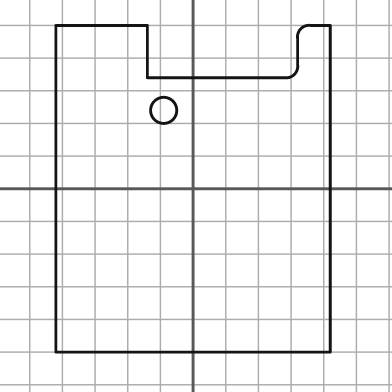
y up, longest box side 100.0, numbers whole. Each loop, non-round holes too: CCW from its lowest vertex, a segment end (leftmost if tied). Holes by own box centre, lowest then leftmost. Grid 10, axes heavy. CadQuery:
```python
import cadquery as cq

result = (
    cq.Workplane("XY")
    .moveTo(-42.0, -50.0)
    .lineTo(42.0, -50.0)
    .lineTo(42.0, 50.0)
    .lineTo(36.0, 50.0)
    .threePointArc((33.0, 49.0), (32.0, 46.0))
    .lineTo(32.0, 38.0)
    .threePointArc((31.0, 35.0), (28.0, 34.0))
    .lineTo(-14.0, 34.0)
    .lineTo(-14.0, 50.0)
    .lineTo(-42.0, 50.0)
    .close()
    .moveTo(-9.0, 24.0)
    .circle(4.0)
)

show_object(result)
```